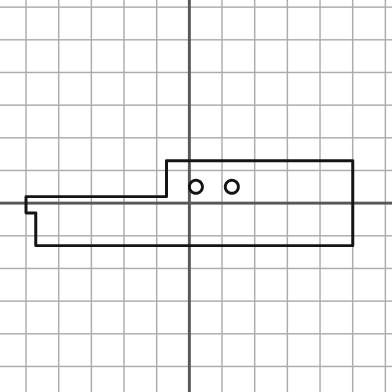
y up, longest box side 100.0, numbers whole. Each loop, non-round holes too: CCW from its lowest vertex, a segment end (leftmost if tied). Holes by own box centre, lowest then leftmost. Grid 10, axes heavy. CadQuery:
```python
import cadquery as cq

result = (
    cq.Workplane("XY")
    .moveTo(-47.0, -13.0)
    .lineTo(50.0, -13.0)
    .lineTo(50.0, 13.0)
    .lineTo(-7.0, 13.0)
    .lineTo(-7.0, 2.0)
    .lineTo(-50.0, 2.0)
    .lineTo(-50.0, -3.0)
    .lineTo(-47.0, -3.0)
    .close()
    .moveTo(2.0, 5.0)
    .circle(2.0)
    .moveTo(13.0, 5.0)
    .circle(2.0)
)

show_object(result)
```